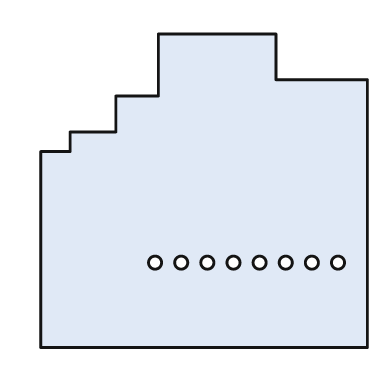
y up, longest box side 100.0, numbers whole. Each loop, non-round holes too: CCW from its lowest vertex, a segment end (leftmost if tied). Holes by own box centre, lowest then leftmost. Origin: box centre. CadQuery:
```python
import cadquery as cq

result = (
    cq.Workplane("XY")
    .moveTo(-50.0, -48.0)
    .lineTo(50.0, -48.0)
    .lineTo(50.0, 34.0)
    .lineTo(22.0, 34.0)
    .lineTo(22.0, 48.0)
    .lineTo(-14.0, 48.0)
    .lineTo(-14.0, 29.0)
    .lineTo(-27.0, 29.0)
    .lineTo(-27.0, 18.0)
    .lineTo(-41.0, 18.0)
    .lineTo(-41.0, 12.0)
    .lineTo(-50.0, 12.0)
    .close()
    .moveTo(-15.0, -22.0)
    .circle(2.0)
    .moveTo(-7.0, -22.0)
    .circle(2.0)
    .moveTo(1.0, -22.0)
    .circle(2.0)
    .moveTo(9.0, -22.0)
    .circle(2.0)
    .moveTo(17.0, -22.0)
    .circle(2.0)
    .moveTo(25.0, -22.0)
    .circle(2.0)
    .moveTo(33.0, -22.0)
    .circle(2.0)
    .moveTo(41.0, -22.0)
    .circle(2.0)
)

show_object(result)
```